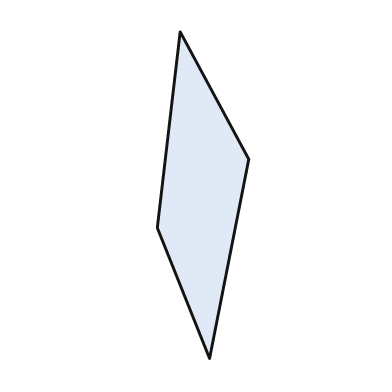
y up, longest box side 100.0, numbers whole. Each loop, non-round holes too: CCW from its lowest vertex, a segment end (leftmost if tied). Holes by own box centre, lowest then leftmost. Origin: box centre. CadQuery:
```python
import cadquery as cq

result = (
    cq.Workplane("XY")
    .moveTo(2.0, -50.0)
    .lineTo(14.0, 11.0)
    .lineTo(-7.0, 50.0)
    .lineTo(-14.0, -10.0)
    .close()
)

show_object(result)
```